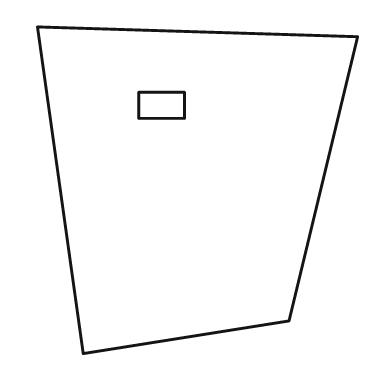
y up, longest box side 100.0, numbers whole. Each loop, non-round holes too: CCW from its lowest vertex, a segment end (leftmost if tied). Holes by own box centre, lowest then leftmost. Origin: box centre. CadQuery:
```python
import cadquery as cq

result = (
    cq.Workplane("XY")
    .moveTo(-35.0, -50.0)
    .lineTo(28.0, -40.0)
    .lineTo(49.0, 47.0)
    .lineTo(-49.0, 50.0)
    .close()
    .moveTo(-18.0, 22.0)
    .lineTo(-4.0, 22.0)
    .lineTo(-4.0, 30.0)
    .lineTo(-18.0, 30.0)
    .close()
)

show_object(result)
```